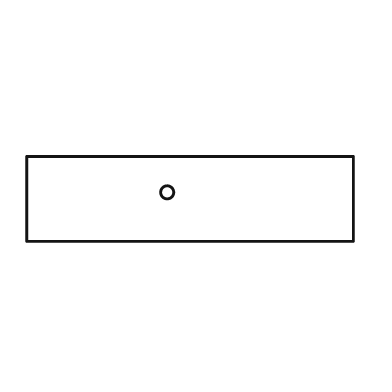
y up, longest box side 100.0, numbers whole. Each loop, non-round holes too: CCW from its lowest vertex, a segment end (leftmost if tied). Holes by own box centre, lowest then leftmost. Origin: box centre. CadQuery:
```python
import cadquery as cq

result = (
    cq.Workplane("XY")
    .moveTo(-50.0, -13.0)
    .lineTo(50.0, -13.0)
    .lineTo(50.0, 13.0)
    .lineTo(-50.0, 13.0)
    .close()
    .moveTo(-7.0, 2.0)
    .circle(2.0)
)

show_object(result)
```